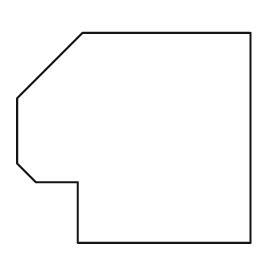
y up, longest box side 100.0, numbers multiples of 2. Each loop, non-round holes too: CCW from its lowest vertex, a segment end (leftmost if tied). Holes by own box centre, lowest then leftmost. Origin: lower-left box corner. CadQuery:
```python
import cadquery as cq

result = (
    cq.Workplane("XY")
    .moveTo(26.0, 0.0)
    .lineTo(100.0, 0.0)
    .lineTo(100.0, 90.0)
    .lineTo(28.0, 90.0)
    .lineTo(0.0, 62.0)
    .lineTo(0.0, 34.0)
    .lineTo(8.0, 26.0)
    .lineTo(26.0, 26.0)
    .close()
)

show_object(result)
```